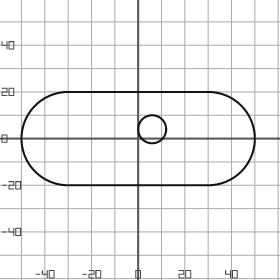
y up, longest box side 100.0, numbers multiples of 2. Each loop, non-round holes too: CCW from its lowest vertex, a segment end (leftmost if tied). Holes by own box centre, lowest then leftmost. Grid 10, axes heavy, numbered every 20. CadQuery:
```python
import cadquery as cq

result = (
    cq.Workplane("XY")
    .moveTo(-30.0, -20.0)
    .lineTo(30.0, -20.0)
    .threePointArc((50.0, 0.0), (30.0, 20.0))
    .lineTo(-30.0, 20.0)
    .threePointArc((-50.0, 0.0), (-30.0, -20.0))
    .close()
    .moveTo(6.0, 4.0)
    .circle(6.0)
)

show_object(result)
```